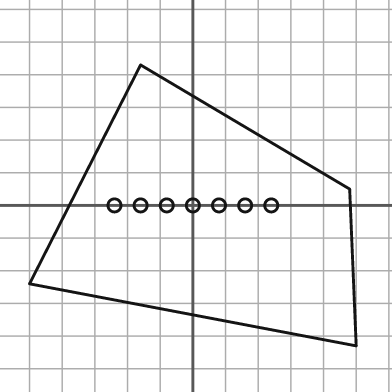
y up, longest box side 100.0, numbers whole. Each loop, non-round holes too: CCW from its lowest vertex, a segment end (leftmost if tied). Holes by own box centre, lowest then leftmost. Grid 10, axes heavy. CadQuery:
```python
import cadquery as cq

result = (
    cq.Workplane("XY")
    .moveTo(50.0, -43.0)
    .lineTo(48.0, 5.0)
    .lineTo(-16.0, 43.0)
    .lineTo(-50.0, -24.0)
    .close()
    .moveTo(-24.0, 0.0)
    .circle(2.0)
    .moveTo(-16.0, 0.0)
    .circle(2.0)
    .moveTo(-8.0, 0.0)
    .circle(2.0)
    .moveTo(0.0, 0.0)
    .circle(2.0)
    .moveTo(8.0, 0.0)
    .circle(2.0)
    .moveTo(16.0, 0.0)
    .circle(2.0)
    .moveTo(24.0, 0.0)
    .circle(2.0)
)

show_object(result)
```